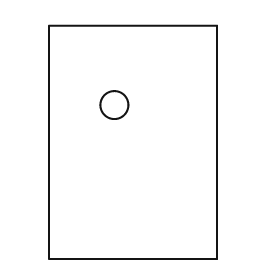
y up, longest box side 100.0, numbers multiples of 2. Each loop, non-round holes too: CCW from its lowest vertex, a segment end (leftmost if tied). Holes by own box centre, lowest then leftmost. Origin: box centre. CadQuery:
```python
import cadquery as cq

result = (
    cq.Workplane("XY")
    .moveTo(-36.0, -50.0)
    .lineTo(36.0, -50.0)
    .lineTo(36.0, 50.0)
    .lineTo(-36.0, 50.0)
    .close()
    .moveTo(-8.0, 16.0)
    .circle(6.0)
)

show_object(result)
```